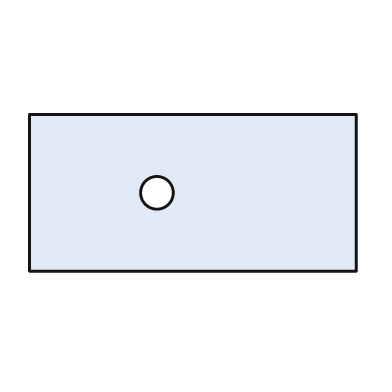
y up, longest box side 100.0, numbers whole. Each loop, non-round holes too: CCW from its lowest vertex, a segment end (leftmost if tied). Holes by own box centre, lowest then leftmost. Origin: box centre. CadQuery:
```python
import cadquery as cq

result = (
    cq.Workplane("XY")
    .moveTo(-50.0, -24.0)
    .lineTo(50.0, -24.0)
    .lineTo(50.0, 24.0)
    .lineTo(-50.0, 24.0)
    .close()
    .moveTo(-11.0, 0.0)
    .circle(5.0)
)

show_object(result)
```